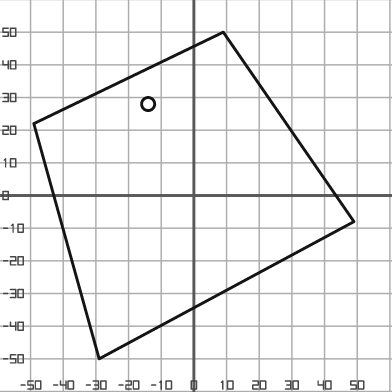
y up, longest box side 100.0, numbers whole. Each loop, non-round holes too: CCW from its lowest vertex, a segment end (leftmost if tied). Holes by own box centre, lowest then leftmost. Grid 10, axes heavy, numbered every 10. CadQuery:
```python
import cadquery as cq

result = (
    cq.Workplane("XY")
    .moveTo(-29.0, -50.0)
    .lineTo(49.0, -8.0)
    .lineTo(9.0, 50.0)
    .lineTo(-49.0, 22.0)
    .close()
    .moveTo(-14.0, 28.0)
    .circle(2.0)
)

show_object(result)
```